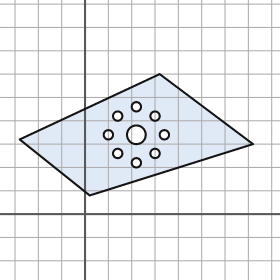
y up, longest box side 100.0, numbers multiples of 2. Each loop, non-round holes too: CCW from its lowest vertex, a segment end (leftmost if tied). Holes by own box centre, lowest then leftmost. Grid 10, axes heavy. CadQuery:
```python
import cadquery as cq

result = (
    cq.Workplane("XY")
    .moveTo(2.0, 8.0)
    .lineTo(72.0, 30.0)
    .lineTo(32.0, 60.0)
    .lineTo(-28.0, 32.0)
    .close()
    .moveTo(22.0, 22.0)
    .circle(2.0)
    .moveTo(14.0, 26.0)
    .circle(2.0)
    .moveTo(30.0, 26.0)
    .circle(2.0)
    .moveTo(10.0, 34.0)
    .circle(2.0)
    .moveTo(22.0, 34.0)
    .circle(4.0)
    .moveTo(34.0, 34.0)
    .circle(2.0)
    .moveTo(14.0, 42.0)
    .circle(2.0)
    .moveTo(30.0, 42.0)
    .circle(2.0)
    .moveTo(22.0, 46.0)
    .circle(2.0)
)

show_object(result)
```